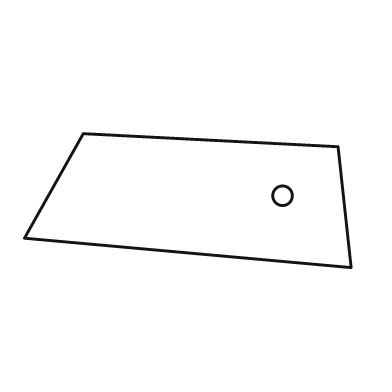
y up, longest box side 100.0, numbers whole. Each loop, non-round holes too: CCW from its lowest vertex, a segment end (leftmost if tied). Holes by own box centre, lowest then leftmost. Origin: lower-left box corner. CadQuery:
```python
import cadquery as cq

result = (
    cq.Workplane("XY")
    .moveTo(100.0, 0.0)
    .lineTo(96.0, 37.0)
    .lineTo(18.0, 41.0)
    .lineTo(0.0, 9.0)
    .close()
    .moveTo(79.0, 22.0)
    .circle(3.0)
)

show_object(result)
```